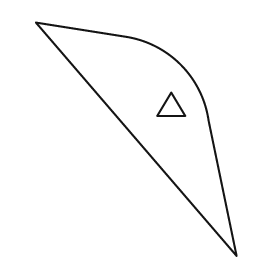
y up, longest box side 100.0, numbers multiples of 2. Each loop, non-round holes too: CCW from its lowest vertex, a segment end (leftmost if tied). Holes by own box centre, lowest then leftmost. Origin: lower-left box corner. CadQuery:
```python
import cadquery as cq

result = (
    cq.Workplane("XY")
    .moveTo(86.0, 0.0)
    .lineTo(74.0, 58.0)
    .threePointArc((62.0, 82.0), (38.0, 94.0))
    .lineTo(0.0, 100.0)
    .close()
    .moveTo(52.0, 60.0)
    .lineTo(64.0, 60.0)
    .lineTo(58.0, 70.0)
    .close()
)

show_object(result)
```